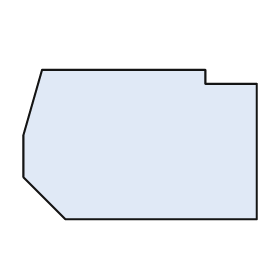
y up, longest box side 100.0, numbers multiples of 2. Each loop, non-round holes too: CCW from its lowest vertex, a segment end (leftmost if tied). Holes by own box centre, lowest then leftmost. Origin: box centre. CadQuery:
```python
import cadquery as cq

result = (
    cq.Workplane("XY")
    .moveTo(-32.0, -32.0)
    .lineTo(50.0, -32.0)
    .lineTo(50.0, 26.0)
    .lineTo(28.0, 26.0)
    .lineTo(28.0, 32.0)
    .lineTo(-42.0, 32.0)
    .lineTo(-50.0, 4.0)
    .lineTo(-50.0, -14.0)
    .close()
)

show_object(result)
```